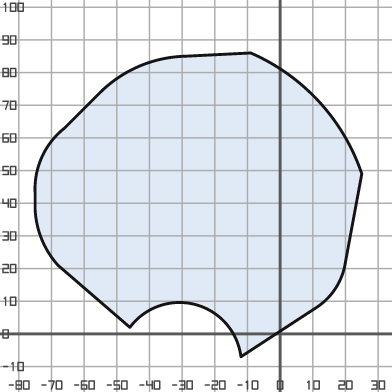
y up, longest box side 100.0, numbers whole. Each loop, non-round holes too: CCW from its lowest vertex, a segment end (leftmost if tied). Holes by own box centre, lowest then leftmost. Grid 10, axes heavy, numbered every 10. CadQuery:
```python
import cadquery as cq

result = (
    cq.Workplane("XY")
    .moveTo(-12.0, -7.0)
    .lineTo(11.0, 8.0)
    .threePointArc((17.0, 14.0), (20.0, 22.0))
    .lineTo(25.0, 49.0)
    .threePointArc((12.0, 71.0), (-9.0, 86.0))
    .lineTo(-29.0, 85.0)
    .threePointArc((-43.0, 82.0), (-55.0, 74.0))
    .lineTo(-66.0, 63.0)
    .threePointArc((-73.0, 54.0), (-75.0, 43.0))
    .lineTo(-75.0, 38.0)
    .threePointArc((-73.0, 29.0), (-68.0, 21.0))
    .lineTo(-46.0, 2.0)
    .threePointArc((-26.0, 9.0), (-12.0, -7.0))
    .close()
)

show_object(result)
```